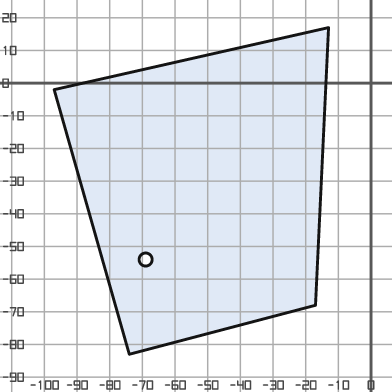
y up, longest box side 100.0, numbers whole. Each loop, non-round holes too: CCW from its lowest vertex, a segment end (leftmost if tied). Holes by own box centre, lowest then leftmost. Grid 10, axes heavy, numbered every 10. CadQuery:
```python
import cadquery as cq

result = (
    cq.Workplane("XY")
    .moveTo(-74.0, -83.0)
    .lineTo(-17.0, -68.0)
    .lineTo(-13.0, 17.0)
    .lineTo(-97.0, -2.0)
    .close()
    .moveTo(-69.0, -54.0)
    .circle(2.0)
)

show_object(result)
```